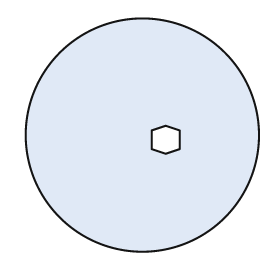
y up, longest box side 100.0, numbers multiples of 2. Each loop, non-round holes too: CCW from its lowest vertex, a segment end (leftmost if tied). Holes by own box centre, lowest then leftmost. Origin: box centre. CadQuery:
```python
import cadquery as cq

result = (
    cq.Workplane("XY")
    .moveTo(0.0, 0.0)
    .circle(50.0)
    .moveTo(10.0, -8.0)
    .lineTo(16.0, -6.0)
    .lineTo(16.0, 2.0)
    .lineTo(10.0, 4.0)
    .lineTo(4.0, 2.0)
    .lineTo(4.0, -6.0)
    .close()
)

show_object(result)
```